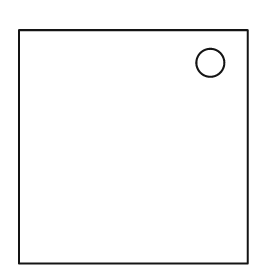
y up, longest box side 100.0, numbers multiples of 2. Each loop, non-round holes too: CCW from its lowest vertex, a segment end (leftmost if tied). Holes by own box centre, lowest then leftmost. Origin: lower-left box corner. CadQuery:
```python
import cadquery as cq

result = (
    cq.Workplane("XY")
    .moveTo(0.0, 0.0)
    .lineTo(98.0, 0.0)
    .lineTo(98.0, 100.0)
    .lineTo(0.0, 100.0)
    .close()
    .moveTo(82.0, 86.0)
    .circle(6.0)
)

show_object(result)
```